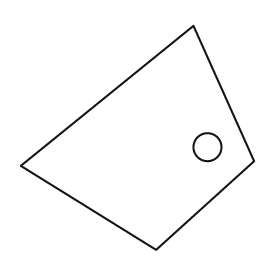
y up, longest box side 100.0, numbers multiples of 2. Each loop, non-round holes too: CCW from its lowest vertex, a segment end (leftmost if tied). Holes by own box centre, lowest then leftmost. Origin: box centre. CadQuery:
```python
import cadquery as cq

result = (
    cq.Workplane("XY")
    .moveTo(8.0, -48.0)
    .lineTo(50.0, -10.0)
    .lineTo(24.0, 48.0)
    .lineTo(-50.0, -12.0)
    .close()
    .moveTo(30.0, -4.0)
    .circle(6.0)
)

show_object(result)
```